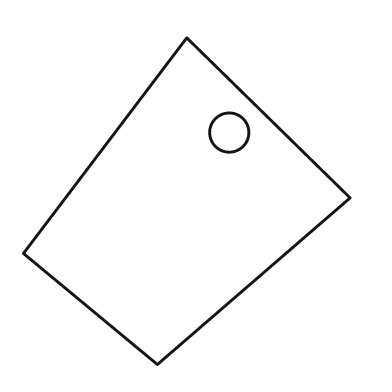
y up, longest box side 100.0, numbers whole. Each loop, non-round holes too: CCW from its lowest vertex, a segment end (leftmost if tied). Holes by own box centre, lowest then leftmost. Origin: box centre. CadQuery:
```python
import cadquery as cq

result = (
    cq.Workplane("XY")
    .moveTo(-9.0, -50.0)
    .lineTo(50.0, 1.0)
    .lineTo(0.0, 50.0)
    .lineTo(-50.0, -16.0)
    .close()
    .moveTo(13.0, 21.0)
    .circle(6.0)
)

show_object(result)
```